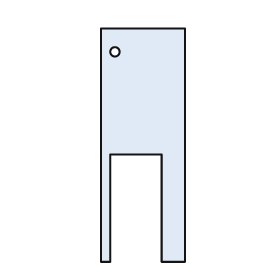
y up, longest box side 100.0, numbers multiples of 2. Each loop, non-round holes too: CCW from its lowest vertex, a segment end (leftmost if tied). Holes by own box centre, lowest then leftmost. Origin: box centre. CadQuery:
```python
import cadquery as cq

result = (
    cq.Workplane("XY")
    .moveTo(-18.0, -50.0)
    .lineTo(-14.0, -50.0)
    .lineTo(-14.0, -4.0)
    .lineTo(8.0, -4.0)
    .lineTo(8.0, -50.0)
    .lineTo(18.0, -50.0)
    .lineTo(18.0, 50.0)
    .lineTo(-18.0, 50.0)
    .close()
    .moveTo(-12.0, 40.0)
    .circle(2.0)
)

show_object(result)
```